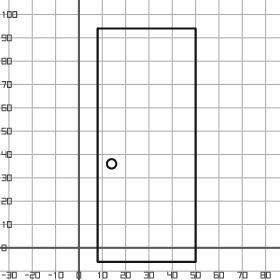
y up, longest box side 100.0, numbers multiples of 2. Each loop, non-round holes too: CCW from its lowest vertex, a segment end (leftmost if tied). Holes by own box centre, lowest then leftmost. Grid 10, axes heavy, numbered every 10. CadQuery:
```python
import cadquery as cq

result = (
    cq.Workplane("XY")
    .moveTo(8.0, -6.0)
    .lineTo(50.0, -6.0)
    .lineTo(50.0, 94.0)
    .lineTo(8.0, 94.0)
    .close()
    .moveTo(14.0, 36.0)
    .circle(2.0)
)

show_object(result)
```